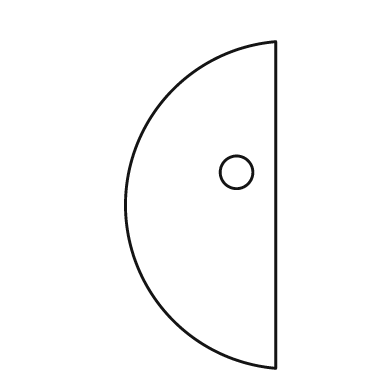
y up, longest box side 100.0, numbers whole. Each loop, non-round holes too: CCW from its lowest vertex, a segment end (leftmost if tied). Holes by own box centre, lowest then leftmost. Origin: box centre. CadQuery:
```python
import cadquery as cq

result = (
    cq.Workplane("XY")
    .moveTo(23.0, -50.0)
    .lineTo(23.0, 50.0)
    .threePointArc((-23.0, 0.0), (23.0, -50.0))
    .close()
    .moveTo(11.0, 10.0)
    .circle(5.0)
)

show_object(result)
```